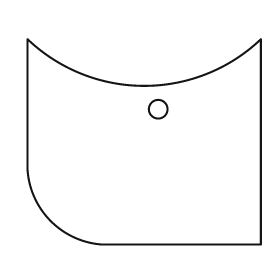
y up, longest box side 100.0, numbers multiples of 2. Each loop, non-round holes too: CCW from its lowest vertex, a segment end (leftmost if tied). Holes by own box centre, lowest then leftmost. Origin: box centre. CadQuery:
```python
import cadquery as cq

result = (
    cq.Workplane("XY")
    .moveTo(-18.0, -44.0)
    .lineTo(50.0, -44.0)
    .lineTo(50.0, 44.0)
    .threePointArc((0.0, 24.0), (-50.0, 44.0))
    .lineTo(-50.0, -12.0)
    .threePointArc((-40.0, -34.0), (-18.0, -44.0))
    .close()
    .moveTo(6.0, 14.0)
    .circle(4.0)
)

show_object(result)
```